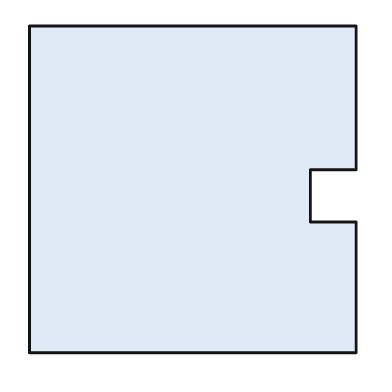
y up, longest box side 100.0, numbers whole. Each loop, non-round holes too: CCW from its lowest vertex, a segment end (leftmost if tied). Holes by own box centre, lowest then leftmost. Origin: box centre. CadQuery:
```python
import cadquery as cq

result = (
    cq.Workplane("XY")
    .moveTo(-50.0, -50.0)
    .lineTo(50.0, -50.0)
    .lineTo(50.0, -10.0)
    .lineTo(36.0, -10.0)
    .lineTo(36.0, 6.0)
    .lineTo(50.0, 6.0)
    .lineTo(50.0, 50.0)
    .lineTo(-50.0, 50.0)
    .close()
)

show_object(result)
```